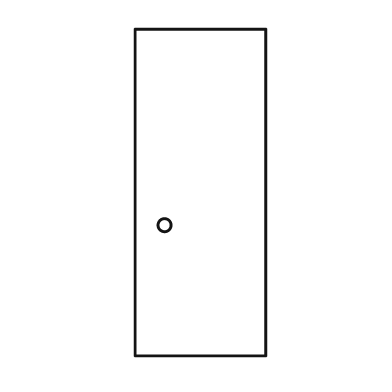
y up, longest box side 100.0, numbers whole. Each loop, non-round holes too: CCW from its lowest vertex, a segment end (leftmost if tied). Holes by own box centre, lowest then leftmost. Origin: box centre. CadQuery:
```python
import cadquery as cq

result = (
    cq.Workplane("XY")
    .moveTo(-20.0, -50.0)
    .lineTo(20.0, -50.0)
    .lineTo(20.0, 50.0)
    .lineTo(-20.0, 50.0)
    .close()
    .moveTo(-11.0, -10.0)
    .circle(2.0)
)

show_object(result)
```